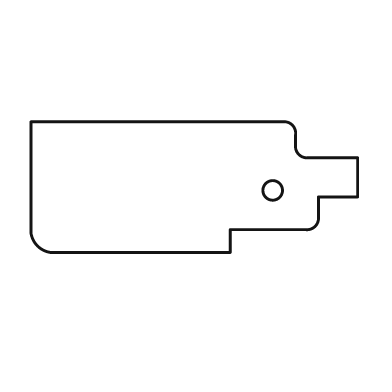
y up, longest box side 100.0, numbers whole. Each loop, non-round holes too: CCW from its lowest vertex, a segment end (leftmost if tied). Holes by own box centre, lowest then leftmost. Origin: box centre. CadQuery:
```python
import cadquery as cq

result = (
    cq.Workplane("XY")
    .moveTo(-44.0, -20.0)
    .lineTo(11.0, -20.0)
    .lineTo(11.0, -13.0)
    .lineTo(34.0, -13.0)
    .threePointArc((37.0, -12.0), (38.0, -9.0))
    .lineTo(38.0, -3.0)
    .lineTo(50.0, -3.0)
    .lineTo(50.0, 9.0)
    .lineTo(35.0, 9.0)
    .threePointArc((32.0, 10.0), (31.0, 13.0))
    .lineTo(31.0, 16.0)
    .threePointArc((30.0, 19.0), (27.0, 20.0))
    .lineTo(-50.0, 20.0)
    .lineTo(-50.0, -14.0)
    .threePointArc((-48.0, -18.0), (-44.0, -20.0))
    .close()
    .moveTo(24.0, -1.0)
    .circle(3.0)
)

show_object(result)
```